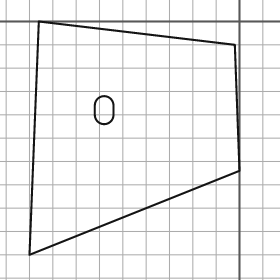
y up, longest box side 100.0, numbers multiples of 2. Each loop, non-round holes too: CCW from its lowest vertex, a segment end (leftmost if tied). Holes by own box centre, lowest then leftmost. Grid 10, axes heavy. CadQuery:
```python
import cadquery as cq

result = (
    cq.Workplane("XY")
    .moveTo(-90.0, -100.0)
    .lineTo(0.0, -64.0)
    .lineTo(-2.0, -10.0)
    .lineTo(-86.0, 0.0)
    .close()
    .moveTo(-62.0, -40.0)
    .threePointArc((-58.0, -44.0), (-54.0, -40.0))
    .lineTo(-54.0, -36.0)
    .threePointArc((-58.0, -32.0), (-62.0, -36.0))
    .close()
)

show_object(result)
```